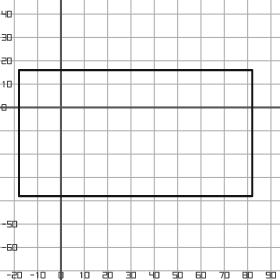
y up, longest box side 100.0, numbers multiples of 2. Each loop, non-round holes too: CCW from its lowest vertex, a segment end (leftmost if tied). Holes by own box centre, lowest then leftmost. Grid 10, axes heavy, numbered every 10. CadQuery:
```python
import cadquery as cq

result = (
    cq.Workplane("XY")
    .moveTo(-18.0, -38.0)
    .lineTo(82.0, -38.0)
    .lineTo(82.0, 16.0)
    .lineTo(-18.0, 16.0)
    .close()
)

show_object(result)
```